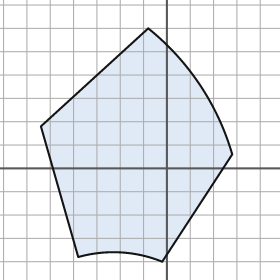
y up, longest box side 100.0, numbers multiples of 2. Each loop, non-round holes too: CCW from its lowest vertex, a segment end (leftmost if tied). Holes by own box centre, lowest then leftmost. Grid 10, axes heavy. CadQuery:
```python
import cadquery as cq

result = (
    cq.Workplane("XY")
    .moveTo(-2.0, -40.0)
    .lineTo(28.0, 6.0)
    .threePointArc((14.0, 36.0), (-8.0, 60.0))
    .lineTo(-54.0, 18.0)
    .lineTo(-38.0, -38.0)
    .threePointArc((-20.0, -36.0), (-2.0, -40.0))
    .close()
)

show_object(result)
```